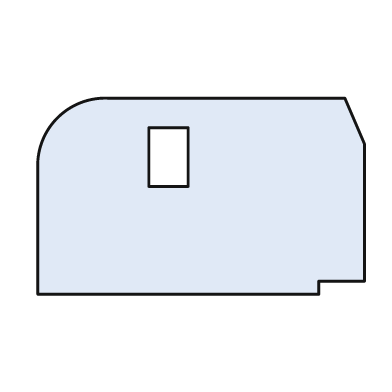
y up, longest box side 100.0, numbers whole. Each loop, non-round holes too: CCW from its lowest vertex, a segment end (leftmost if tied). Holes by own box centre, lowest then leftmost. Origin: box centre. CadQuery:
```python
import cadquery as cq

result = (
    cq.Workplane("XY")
    .moveTo(-50.0, -30.0)
    .lineTo(36.0, -30.0)
    .lineTo(36.0, -26.0)
    .lineTo(50.0, -26.0)
    .lineTo(50.0, 16.0)
    .lineTo(44.0, 30.0)
    .lineTo(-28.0, 30.0)
    .threePointArc((-44.0, 24.0), (-50.0, 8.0))
    .close()
    .moveTo(-16.0, 3.0)
    .lineTo(-4.0, 3.0)
    .lineTo(-4.0, 21.0)
    .lineTo(-16.0, 21.0)
    .close()
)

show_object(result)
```